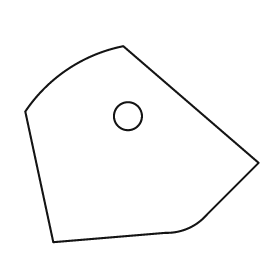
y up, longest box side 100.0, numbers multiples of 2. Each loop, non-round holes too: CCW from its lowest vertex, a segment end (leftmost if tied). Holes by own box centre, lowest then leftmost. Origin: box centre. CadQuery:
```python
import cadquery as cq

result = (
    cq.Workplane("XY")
    .moveTo(-38.0, -42.0)
    .lineTo(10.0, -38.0)
    .threePointArc((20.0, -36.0), (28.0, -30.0))
    .lineTo(50.0, -8.0)
    .lineTo(-8.0, 42.0)
    .threePointArc((-32.0, 32.0), (-50.0, 14.0))
    .close()
    .moveTo(-6.0, 12.0)
    .circle(6.0)
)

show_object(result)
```